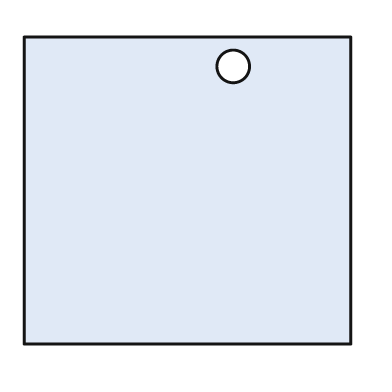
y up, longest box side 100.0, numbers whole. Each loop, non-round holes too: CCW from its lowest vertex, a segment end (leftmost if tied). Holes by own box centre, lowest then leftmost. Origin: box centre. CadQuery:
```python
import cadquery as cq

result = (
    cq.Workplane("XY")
    .moveTo(-50.0, -47.0)
    .lineTo(50.0, -47.0)
    .lineTo(50.0, 47.0)
    .lineTo(-50.0, 47.0)
    .close()
    .moveTo(14.0, 38.0)
    .circle(5.0)
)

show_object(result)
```